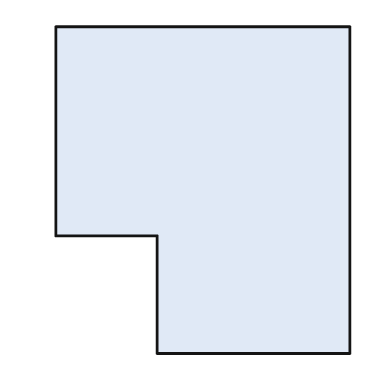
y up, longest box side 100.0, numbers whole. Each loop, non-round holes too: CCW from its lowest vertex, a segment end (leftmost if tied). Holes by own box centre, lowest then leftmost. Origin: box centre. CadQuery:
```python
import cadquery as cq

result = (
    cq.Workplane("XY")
    .moveTo(-14.0, -50.0)
    .lineTo(45.0, -50.0)
    .lineTo(45.0, 50.0)
    .lineTo(-45.0, 50.0)
    .lineTo(-45.0, -14.0)
    .lineTo(-14.0, -14.0)
    .close()
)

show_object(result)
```